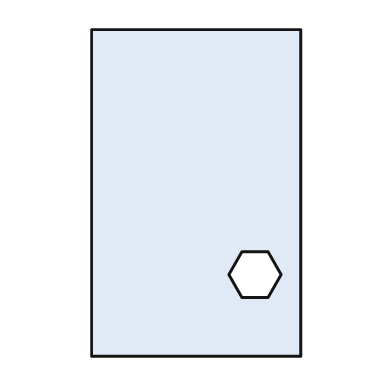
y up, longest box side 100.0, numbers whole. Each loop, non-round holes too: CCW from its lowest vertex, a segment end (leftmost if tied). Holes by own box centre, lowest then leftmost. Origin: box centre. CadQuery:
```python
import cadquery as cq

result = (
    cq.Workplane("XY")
    .moveTo(-32.0, -50.0)
    .lineTo(32.0, -50.0)
    .lineTo(32.0, 50.0)
    .lineTo(-32.0, 50.0)
    .close()
    .moveTo(14.0, -32.0)
    .lineTo(22.0, -32.0)
    .lineTo(26.0, -25.0)
    .lineTo(22.0, -18.0)
    .lineTo(14.0, -18.0)
    .lineTo(10.0, -25.0)
    .close()
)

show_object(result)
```